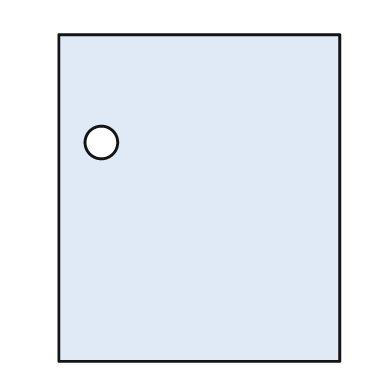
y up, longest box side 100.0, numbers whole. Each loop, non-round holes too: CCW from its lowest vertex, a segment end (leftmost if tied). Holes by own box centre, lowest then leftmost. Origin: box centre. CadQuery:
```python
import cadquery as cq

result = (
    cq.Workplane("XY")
    .moveTo(-43.0, -50.0)
    .lineTo(43.0, -50.0)
    .lineTo(43.0, 50.0)
    .lineTo(-43.0, 50.0)
    .close()
    .moveTo(-30.0, 17.0)
    .circle(5.0)
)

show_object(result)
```